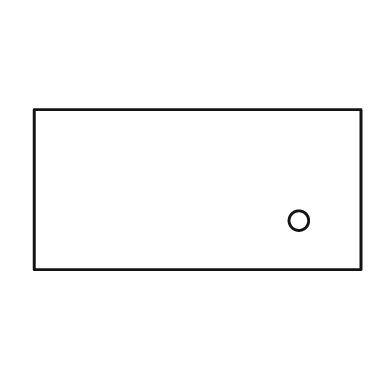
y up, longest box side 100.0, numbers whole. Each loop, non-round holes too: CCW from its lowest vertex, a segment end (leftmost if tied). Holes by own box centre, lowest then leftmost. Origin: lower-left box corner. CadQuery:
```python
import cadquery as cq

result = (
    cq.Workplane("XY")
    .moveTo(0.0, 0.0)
    .lineTo(100.0, 0.0)
    .lineTo(100.0, 49.0)
    .lineTo(0.0, 49.0)
    .close()
    .moveTo(81.0, 15.0)
    .circle(3.0)
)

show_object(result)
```